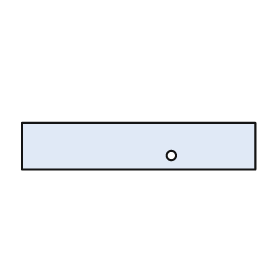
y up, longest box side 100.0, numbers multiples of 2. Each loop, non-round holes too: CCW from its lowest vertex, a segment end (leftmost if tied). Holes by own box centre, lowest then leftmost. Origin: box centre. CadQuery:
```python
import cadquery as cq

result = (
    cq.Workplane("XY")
    .moveTo(-50.0, -10.0)
    .lineTo(50.0, -10.0)
    .lineTo(50.0, 10.0)
    .lineTo(-50.0, 10.0)
    .close()
    .moveTo(14.0, -4.0)
    .circle(2.0)
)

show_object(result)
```